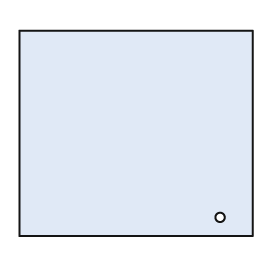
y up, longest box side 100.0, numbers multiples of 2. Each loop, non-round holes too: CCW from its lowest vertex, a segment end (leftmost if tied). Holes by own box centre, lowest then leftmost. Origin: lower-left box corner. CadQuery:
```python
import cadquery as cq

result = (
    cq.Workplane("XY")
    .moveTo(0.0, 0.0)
    .lineTo(100.0, 0.0)
    .lineTo(100.0, 88.0)
    .lineTo(0.0, 88.0)
    .close()
    .moveTo(86.0, 8.0)
    .circle(2.0)
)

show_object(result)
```